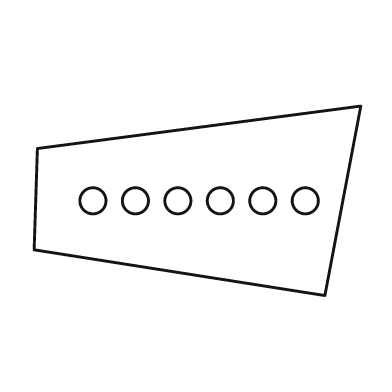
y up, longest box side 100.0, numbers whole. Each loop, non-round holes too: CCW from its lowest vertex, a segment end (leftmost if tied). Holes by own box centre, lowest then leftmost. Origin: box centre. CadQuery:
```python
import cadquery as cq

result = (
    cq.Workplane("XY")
    .moveTo(39.0, -29.0)
    .lineTo(50.0, 29.0)
    .lineTo(-49.0, 16.0)
    .lineTo(-50.0, -15.0)
    .close()
    .moveTo(-32.0, 0.0)
    .circle(4.0)
    .moveTo(-19.0, 0.0)
    .circle(4.0)
    .moveTo(-6.0, 0.0)
    .circle(4.0)
    .moveTo(7.0, 0.0)
    .circle(4.0)
    .moveTo(20.0, 0.0)
    .circle(4.0)
    .moveTo(33.0, 0.0)
    .circle(4.0)
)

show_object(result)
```